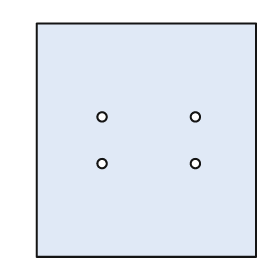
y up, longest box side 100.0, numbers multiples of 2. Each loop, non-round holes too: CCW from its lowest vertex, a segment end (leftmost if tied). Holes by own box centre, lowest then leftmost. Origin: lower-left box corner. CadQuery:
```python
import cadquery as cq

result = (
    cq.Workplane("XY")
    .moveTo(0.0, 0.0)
    .lineTo(94.0, 0.0)
    .lineTo(94.0, 100.0)
    .lineTo(0.0, 100.0)
    .close()
    .moveTo(28.0, 40.0)
    .circle(2.0)
    .moveTo(68.0, 40.0)
    .circle(2.0)
    .moveTo(28.0, 60.0)
    .circle(2.0)
    .moveTo(68.0, 60.0)
    .circle(2.0)
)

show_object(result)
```